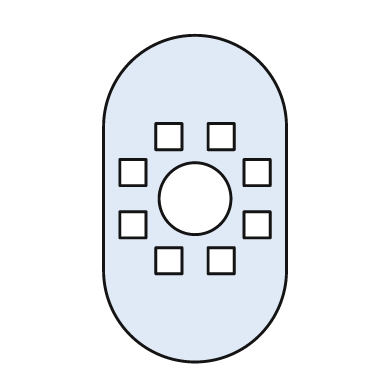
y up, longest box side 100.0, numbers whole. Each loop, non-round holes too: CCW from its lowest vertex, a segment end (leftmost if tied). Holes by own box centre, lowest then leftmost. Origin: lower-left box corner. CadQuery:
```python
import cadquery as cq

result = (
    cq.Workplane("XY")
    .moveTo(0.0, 28.0)
    .threePointArc((28.0, 0.0), (56.0, 28.0))
    .lineTo(56.0, 72.0)
    .threePointArc((28.0, 100.0), (0.0, 72.0))
    .close()
    .moveTo(16.0, 27.0)
    .lineTo(24.0, 27.0)
    .lineTo(24.0, 35.0)
    .lineTo(16.0, 35.0)
    .close()
    .moveTo(32.0, 27.0)
    .lineTo(40.0, 27.0)
    .lineTo(40.0, 35.0)
    .lineTo(32.0, 35.0)
    .close()
    .moveTo(5.0, 38.0)
    .lineTo(13.0, 38.0)
    .lineTo(13.0, 46.0)
    .lineTo(5.0, 46.0)
    .close()
    .moveTo(43.0, 38.0)
    .lineTo(51.0, 38.0)
    .lineTo(51.0, 46.0)
    .lineTo(43.0, 46.0)
    .close()
    .moveTo(28.0, 50.0)
    .circle(11.0)
    .moveTo(5.0, 54.0)
    .lineTo(13.0, 54.0)
    .lineTo(13.0, 62.0)
    .lineTo(5.0, 62.0)
    .close()
    .moveTo(43.0, 54.0)
    .lineTo(51.0, 54.0)
    .lineTo(51.0, 62.0)
    .lineTo(43.0, 62.0)
    .close()
    .moveTo(16.0, 65.0)
    .lineTo(24.0, 65.0)
    .lineTo(24.0, 73.0)
    .lineTo(16.0, 73.0)
    .close()
    .moveTo(32.0, 65.0)
    .lineTo(40.0, 65.0)
    .lineTo(40.0, 73.0)
    .lineTo(32.0, 73.0)
    .close()
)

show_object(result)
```